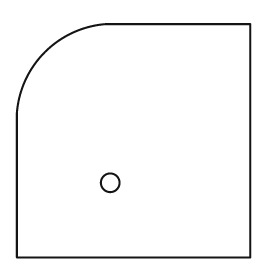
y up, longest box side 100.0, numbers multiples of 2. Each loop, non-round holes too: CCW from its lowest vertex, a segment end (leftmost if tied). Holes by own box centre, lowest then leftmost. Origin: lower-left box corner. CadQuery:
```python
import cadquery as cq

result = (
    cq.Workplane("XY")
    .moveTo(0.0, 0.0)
    .lineTo(100.0, 0.0)
    .lineTo(100.0, 100.0)
    .lineTo(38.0, 100.0)
    .threePointArc((12.0, 88.0), (0.0, 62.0))
    .close()
    .moveTo(40.0, 32.0)
    .circle(4.0)
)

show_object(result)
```